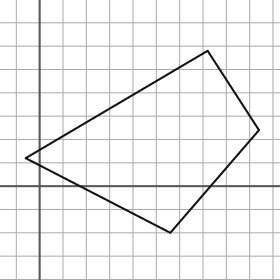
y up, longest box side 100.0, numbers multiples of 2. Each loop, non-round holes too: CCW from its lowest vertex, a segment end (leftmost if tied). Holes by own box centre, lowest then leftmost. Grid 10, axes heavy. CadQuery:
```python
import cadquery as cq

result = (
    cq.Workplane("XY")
    .moveTo(56.0, -20.0)
    .lineTo(94.0, 24.0)
    .lineTo(72.0, 58.0)
    .lineTo(-6.0, 12.0)
    .close()
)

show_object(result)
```